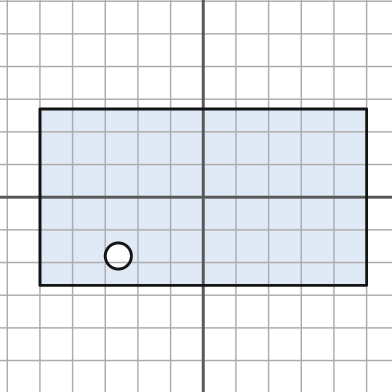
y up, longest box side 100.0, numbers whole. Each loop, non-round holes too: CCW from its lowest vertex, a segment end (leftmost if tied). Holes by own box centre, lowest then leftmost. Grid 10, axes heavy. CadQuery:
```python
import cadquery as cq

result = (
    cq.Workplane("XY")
    .moveTo(-50.0, -27.0)
    .lineTo(50.0, -27.0)
    .lineTo(50.0, 27.0)
    .lineTo(-50.0, 27.0)
    .close()
    .moveTo(-26.0, -18.0)
    .circle(4.0)
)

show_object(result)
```